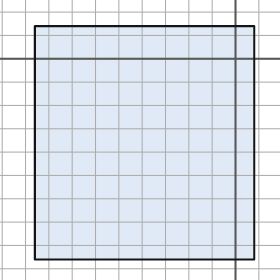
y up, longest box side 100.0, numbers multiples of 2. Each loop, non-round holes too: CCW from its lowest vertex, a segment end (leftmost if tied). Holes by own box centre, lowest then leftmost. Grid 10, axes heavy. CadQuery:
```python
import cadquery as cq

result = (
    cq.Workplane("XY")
    .moveTo(-86.0, -86.0)
    .lineTo(8.0, -86.0)
    .lineTo(8.0, 14.0)
    .lineTo(-86.0, 14.0)
    .close()
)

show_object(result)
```